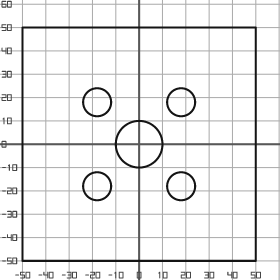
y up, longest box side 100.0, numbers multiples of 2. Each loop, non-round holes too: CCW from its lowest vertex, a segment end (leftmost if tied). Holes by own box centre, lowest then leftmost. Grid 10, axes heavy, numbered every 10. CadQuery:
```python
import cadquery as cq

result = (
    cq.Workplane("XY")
    .moveTo(-50.0, -50.0)
    .lineTo(50.0, -50.0)
    .lineTo(50.0, 50.0)
    .lineTo(-50.0, 50.0)
    .close()
    .moveTo(-18.0, -18.0)
    .circle(6.0)
    .moveTo(18.0, -18.0)
    .circle(6.0)
    .moveTo(0.0, 0.0)
    .circle(10.0)
    .moveTo(-18.0, 18.0)
    .circle(6.0)
    .moveTo(18.0, 18.0)
    .circle(6.0)
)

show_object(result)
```